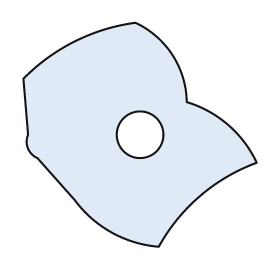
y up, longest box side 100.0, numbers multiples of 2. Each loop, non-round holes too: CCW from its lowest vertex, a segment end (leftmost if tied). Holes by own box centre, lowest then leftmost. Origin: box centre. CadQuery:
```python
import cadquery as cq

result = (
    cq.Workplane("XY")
    .moveTo(8.0, -48.0)
    .threePointArc((26.0, -26.0), (50.0, -12.0))
    .threePointArc((38.0, 4.0), (20.0, 14.0))
    .threePointArc((14.0, 34.0), (-2.0, 48.0))
    .threePointArc((-28.0, 40.0), (-50.0, 24.0))
    .lineTo(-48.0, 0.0)
    .threePointArc((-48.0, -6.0), (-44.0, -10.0))
    .lineTo(-28.0, -28.0)
    .threePointArc((-12.0, -42.0), (8.0, -48.0))
    .close()
    .moveTo(0.0, 0.0)
    .circle(10.0)
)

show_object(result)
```